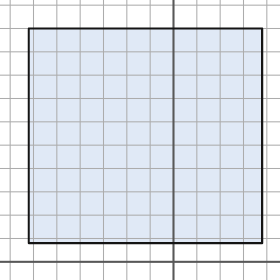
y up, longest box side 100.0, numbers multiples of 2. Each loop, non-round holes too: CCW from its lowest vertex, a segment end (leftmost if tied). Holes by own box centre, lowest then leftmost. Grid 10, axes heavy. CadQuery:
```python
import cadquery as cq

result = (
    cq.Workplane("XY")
    .moveTo(-62.0, 8.0)
    .lineTo(38.0, 8.0)
    .lineTo(38.0, 100.0)
    .lineTo(-62.0, 100.0)
    .close()
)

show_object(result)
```